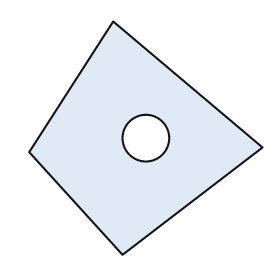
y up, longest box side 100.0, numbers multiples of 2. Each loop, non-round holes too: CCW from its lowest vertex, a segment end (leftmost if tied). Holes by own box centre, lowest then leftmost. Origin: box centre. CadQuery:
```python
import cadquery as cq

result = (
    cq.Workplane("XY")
    .moveTo(-10.0, -50.0)
    .lineTo(50.0, -4.0)
    .lineTo(-14.0, 50.0)
    .lineTo(-50.0, -6.0)
    .close()
    .moveTo(0.0, 0.0)
    .circle(10.0)
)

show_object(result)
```